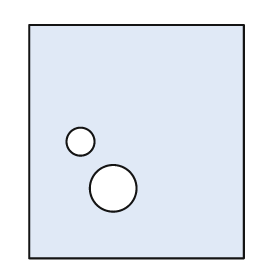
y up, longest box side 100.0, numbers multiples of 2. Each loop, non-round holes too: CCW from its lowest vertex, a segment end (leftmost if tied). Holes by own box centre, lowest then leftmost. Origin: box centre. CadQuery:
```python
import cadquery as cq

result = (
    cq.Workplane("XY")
    .moveTo(-46.0, -50.0)
    .lineTo(46.0, -50.0)
    .lineTo(46.0, 50.0)
    .lineTo(-46.0, 50.0)
    .close()
    .moveTo(-10.0, -20.0)
    .circle(10.0)
    .moveTo(-24.0, 0.0)
    .circle(6.0)
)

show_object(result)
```